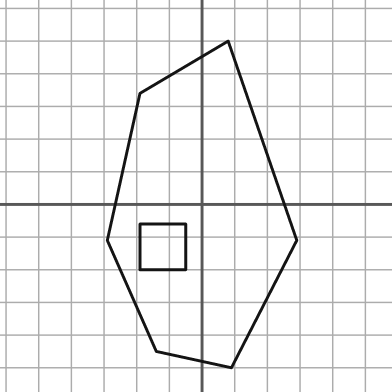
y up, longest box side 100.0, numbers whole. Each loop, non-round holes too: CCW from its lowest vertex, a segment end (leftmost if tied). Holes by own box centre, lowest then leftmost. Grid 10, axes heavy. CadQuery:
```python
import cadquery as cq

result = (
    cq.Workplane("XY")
    .moveTo(9.0, -50.0)
    .lineTo(29.0, -11.0)
    .lineTo(8.0, 50.0)
    .lineTo(-19.0, 34.0)
    .lineTo(-29.0, -11.0)
    .lineTo(-14.0, -45.0)
    .close()
    .moveTo(-19.0, -20.0)
    .lineTo(-5.0, -20.0)
    .lineTo(-5.0, -6.0)
    .lineTo(-19.0, -6.0)
    .close()
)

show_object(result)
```